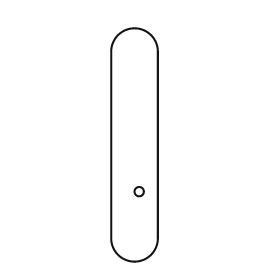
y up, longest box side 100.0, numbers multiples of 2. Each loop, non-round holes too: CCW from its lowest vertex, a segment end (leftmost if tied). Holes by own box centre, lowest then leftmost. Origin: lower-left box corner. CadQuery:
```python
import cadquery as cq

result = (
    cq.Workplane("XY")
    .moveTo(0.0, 10.0)
    .threePointArc((10.0, 0.0), (20.0, 10.0))
    .lineTo(20.0, 90.0)
    .threePointArc((10.0, 100.0), (0.0, 90.0))
    .close()
    .moveTo(12.0, 30.0)
    .circle(2.0)
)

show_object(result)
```